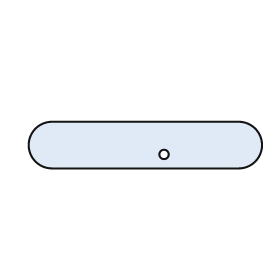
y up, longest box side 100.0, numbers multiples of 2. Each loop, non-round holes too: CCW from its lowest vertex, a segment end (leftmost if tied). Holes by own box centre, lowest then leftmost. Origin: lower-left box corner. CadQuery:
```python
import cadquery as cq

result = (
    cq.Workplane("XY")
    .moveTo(10.0, 0.0)
    .lineTo(90.0, 0.0)
    .threePointArc((100.0, 10.0), (90.0, 20.0))
    .lineTo(10.0, 20.0)
    .threePointArc((0.0, 10.0), (10.0, 0.0))
    .close()
    .moveTo(58.0, 6.0)
    .circle(2.0)
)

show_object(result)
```